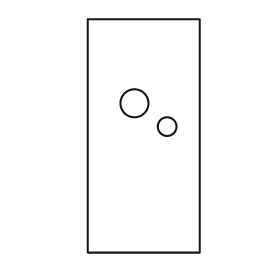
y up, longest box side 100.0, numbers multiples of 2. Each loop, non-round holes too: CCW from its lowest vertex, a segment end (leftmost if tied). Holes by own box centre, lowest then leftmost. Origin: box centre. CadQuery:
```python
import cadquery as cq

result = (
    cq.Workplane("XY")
    .moveTo(-24.0, -50.0)
    .lineTo(24.0, -50.0)
    .lineTo(24.0, 50.0)
    .lineTo(-24.0, 50.0)
    .close()
    .moveTo(10.0, 4.0)
    .circle(4.0)
    .moveTo(-4.0, 14.0)
    .circle(6.0)
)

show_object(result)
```